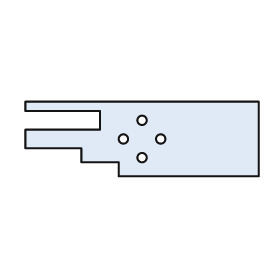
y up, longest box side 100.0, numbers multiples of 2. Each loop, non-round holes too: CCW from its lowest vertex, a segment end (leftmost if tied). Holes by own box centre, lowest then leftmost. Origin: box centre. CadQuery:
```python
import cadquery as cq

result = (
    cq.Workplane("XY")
    .moveTo(-10.0, -16.0)
    .lineTo(50.0, -16.0)
    .lineTo(50.0, 16.0)
    .lineTo(-50.0, 16.0)
    .lineTo(-50.0, 12.0)
    .lineTo(-18.0, 12.0)
    .lineTo(-18.0, 4.0)
    .lineTo(-50.0, 4.0)
    .lineTo(-50.0, -4.0)
    .lineTo(-26.0, -4.0)
    .lineTo(-26.0, -10.0)
    .lineTo(-10.0, -10.0)
    .close()
    .moveTo(0.0, -8.0)
    .circle(2.0)
    .moveTo(-8.0, 0.0)
    .circle(2.0)
    .moveTo(8.0, 0.0)
    .circle(2.0)
    .moveTo(0.0, 8.0)
    .circle(2.0)
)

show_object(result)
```